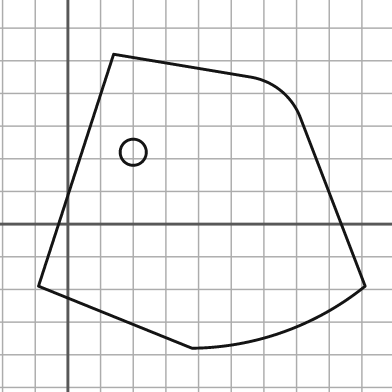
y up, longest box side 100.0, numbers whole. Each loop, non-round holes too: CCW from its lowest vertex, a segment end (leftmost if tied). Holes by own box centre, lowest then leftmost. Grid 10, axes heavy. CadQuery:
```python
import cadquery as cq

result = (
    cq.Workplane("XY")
    .moveTo(38.0, -38.0)
    .threePointArc((66.0, -33.0), (91.0, -19.0))
    .lineTo(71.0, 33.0)
    .threePointArc((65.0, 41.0), (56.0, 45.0))
    .lineTo(14.0, 52.0)
    .lineTo(-9.0, -19.0)
    .close()
    .moveTo(20.0, 22.0)
    .circle(4.0)
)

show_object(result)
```